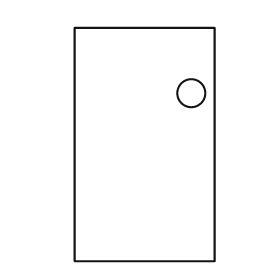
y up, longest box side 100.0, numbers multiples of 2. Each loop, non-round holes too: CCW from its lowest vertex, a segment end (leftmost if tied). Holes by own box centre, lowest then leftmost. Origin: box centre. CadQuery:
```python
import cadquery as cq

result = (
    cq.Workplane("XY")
    .moveTo(-30.0, -50.0)
    .lineTo(30.0, -50.0)
    .lineTo(30.0, 50.0)
    .lineTo(-30.0, 50.0)
    .close()
    .moveTo(20.0, 22.0)
    .circle(6.0)
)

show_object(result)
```